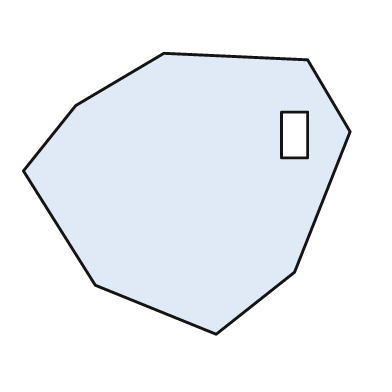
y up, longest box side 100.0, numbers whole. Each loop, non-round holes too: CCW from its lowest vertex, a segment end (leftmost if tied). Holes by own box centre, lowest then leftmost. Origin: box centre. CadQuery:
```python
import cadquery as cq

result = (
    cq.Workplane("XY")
    .moveTo(9.0, -43.0)
    .lineTo(33.0, -24.0)
    .lineTo(50.0, 19.0)
    .lineTo(37.0, 41.0)
    .lineTo(-7.0, 43.0)
    .lineTo(-34.0, 27.0)
    .lineTo(-50.0, 7.0)
    .lineTo(-28.0, -28.0)
    .close()
    .moveTo(29.0, 11.0)
    .lineTo(37.0, 11.0)
    .lineTo(37.0, 25.0)
    .lineTo(29.0, 25.0)
    .close()
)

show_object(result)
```